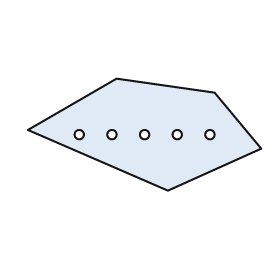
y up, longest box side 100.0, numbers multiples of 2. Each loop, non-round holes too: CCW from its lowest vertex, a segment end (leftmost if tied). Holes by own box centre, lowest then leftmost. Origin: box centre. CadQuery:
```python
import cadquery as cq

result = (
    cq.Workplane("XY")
    .moveTo(10.0, -24.0)
    .lineTo(50.0, -6.0)
    .lineTo(30.0, 18.0)
    .lineTo(-12.0, 24.0)
    .lineTo(-50.0, 2.0)
    .close()
    .moveTo(-28.0, 0.0)
    .circle(2.0)
    .moveTo(-14.0, 0.0)
    .circle(2.0)
    .moveTo(0.0, 0.0)
    .circle(2.0)
    .moveTo(14.0, 0.0)
    .circle(2.0)
    .moveTo(28.0, 0.0)
    .circle(2.0)
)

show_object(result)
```